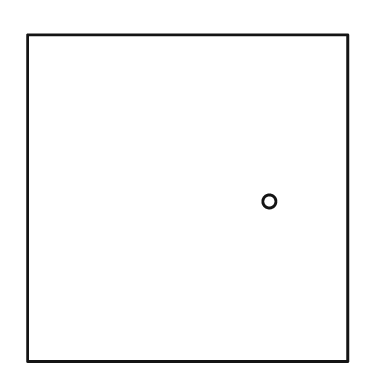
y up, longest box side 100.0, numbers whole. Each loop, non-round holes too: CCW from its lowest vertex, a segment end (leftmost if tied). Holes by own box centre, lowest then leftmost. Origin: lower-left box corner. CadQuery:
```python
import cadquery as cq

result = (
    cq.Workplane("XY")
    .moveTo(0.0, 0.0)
    .lineTo(98.0, 0.0)
    .lineTo(98.0, 100.0)
    .lineTo(0.0, 100.0)
    .close()
    .moveTo(74.0, 49.0)
    .circle(2.0)
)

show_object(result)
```